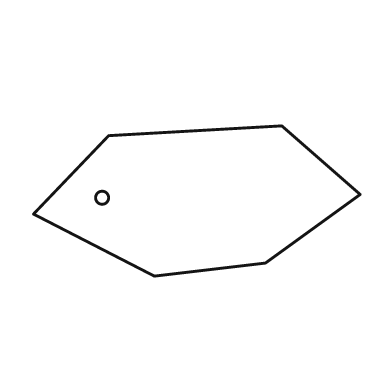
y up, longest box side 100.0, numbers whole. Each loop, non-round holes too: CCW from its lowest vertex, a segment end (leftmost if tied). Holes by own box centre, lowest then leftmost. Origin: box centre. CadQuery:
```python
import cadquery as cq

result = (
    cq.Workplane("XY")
    .moveTo(-13.0, -23.0)
    .lineTo(21.0, -19.0)
    .lineTo(50.0, 2.0)
    .lineTo(26.0, 23.0)
    .lineTo(-27.0, 20.0)
    .lineTo(-50.0, -4.0)
    .close()
    .moveTo(-29.0, 1.0)
    .circle(2.0)
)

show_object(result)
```